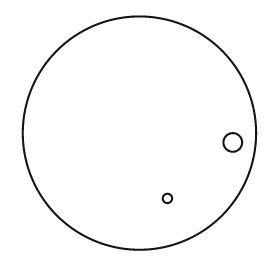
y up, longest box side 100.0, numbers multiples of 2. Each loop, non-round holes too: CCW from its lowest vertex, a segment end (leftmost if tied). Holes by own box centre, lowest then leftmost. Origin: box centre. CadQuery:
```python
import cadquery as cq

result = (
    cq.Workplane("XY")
    .moveTo(0.0, 0.0)
    .circle(50.0)
    .moveTo(12.0, -28.0)
    .circle(2.0)
    .moveTo(40.0, -4.0)
    .circle(4.0)
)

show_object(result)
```